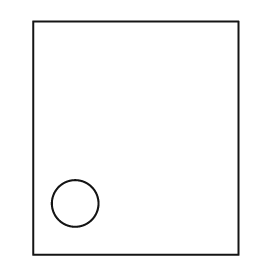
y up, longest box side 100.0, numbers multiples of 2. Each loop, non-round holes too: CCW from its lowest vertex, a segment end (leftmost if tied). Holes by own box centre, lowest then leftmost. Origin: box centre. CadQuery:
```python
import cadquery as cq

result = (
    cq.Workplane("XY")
    .moveTo(-44.0, -50.0)
    .lineTo(44.0, -50.0)
    .lineTo(44.0, 50.0)
    .lineTo(-44.0, 50.0)
    .close()
    .moveTo(-26.0, -28.0)
    .circle(10.0)
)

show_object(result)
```